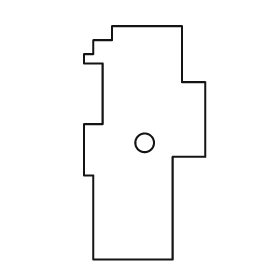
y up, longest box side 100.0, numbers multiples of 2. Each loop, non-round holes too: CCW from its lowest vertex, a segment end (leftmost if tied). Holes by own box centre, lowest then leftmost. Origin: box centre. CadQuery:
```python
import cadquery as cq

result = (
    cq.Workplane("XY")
    .moveTo(-22.0, -50.0)
    .lineTo(12.0, -50.0)
    .lineTo(12.0, -6.0)
    .lineTo(26.0, -6.0)
    .lineTo(26.0, 26.0)
    .lineTo(16.0, 26.0)
    .lineTo(16.0, 50.0)
    .lineTo(-14.0, 50.0)
    .lineTo(-14.0, 44.0)
    .lineTo(-22.0, 44.0)
    .lineTo(-22.0, 38.0)
    .lineTo(-26.0, 38.0)
    .lineTo(-26.0, 34.0)
    .lineTo(-18.0, 34.0)
    .lineTo(-18.0, 8.0)
    .lineTo(-26.0, 8.0)
    .lineTo(-26.0, -14.0)
    .lineTo(-22.0, -14.0)
    .close()
    .moveTo(0.0, 0.0)
    .circle(4.0)
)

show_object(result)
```